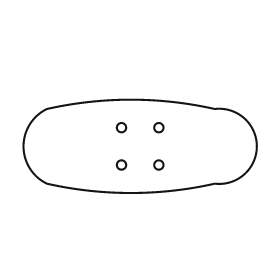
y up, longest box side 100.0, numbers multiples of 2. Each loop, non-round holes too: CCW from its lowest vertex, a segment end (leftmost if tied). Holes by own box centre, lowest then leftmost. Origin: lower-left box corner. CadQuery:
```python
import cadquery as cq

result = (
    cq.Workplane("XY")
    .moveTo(10.0, 4.0)
    .threePointArc((46.0, 0.0), (82.0, 4.0))
    .threePointArc((100.0, 20.0), (82.0, 36.0))
    .threePointArc((46.0, 40.0), (10.0, 36.0))
    .threePointArc((0.0, 20.0), (10.0, 4.0))
    .close()
    .moveTo(42.0, 12.0)
    .circle(2.0)
    .moveTo(58.0, 12.0)
    .circle(2.0)
    .moveTo(42.0, 28.0)
    .circle(2.0)
    .moveTo(58.0, 28.0)
    .circle(2.0)
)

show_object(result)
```